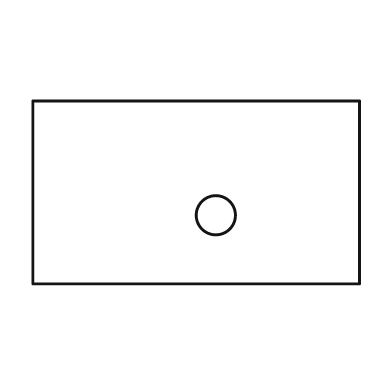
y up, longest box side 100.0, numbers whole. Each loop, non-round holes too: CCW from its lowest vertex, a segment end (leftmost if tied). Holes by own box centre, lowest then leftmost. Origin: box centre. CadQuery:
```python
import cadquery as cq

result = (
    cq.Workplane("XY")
    .moveTo(-50.0, -28.0)
    .lineTo(50.0, -28.0)
    .lineTo(50.0, 28.0)
    .lineTo(-50.0, 28.0)
    .close()
    .moveTo(6.0, -7.0)
    .circle(6.0)
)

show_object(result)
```